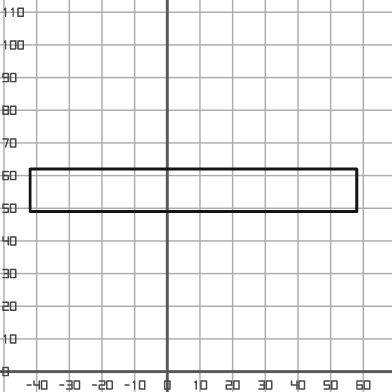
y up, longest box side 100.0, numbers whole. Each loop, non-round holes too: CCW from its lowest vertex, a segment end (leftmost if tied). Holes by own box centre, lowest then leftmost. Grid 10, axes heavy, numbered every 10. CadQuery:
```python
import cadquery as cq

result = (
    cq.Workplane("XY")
    .moveTo(-42.0, 49.0)
    .lineTo(58.0, 49.0)
    .lineTo(58.0, 62.0)
    .lineTo(-42.0, 62.0)
    .close()
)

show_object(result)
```